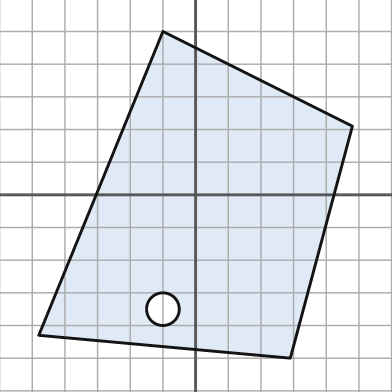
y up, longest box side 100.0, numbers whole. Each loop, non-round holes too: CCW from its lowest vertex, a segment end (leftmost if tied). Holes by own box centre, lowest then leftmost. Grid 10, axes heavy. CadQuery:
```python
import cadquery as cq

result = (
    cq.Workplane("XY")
    .moveTo(29.0, -50.0)
    .lineTo(48.0, 21.0)
    .lineTo(-10.0, 50.0)
    .lineTo(-48.0, -43.0)
    .close()
    .moveTo(-10.0, -35.0)
    .circle(5.0)
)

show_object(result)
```